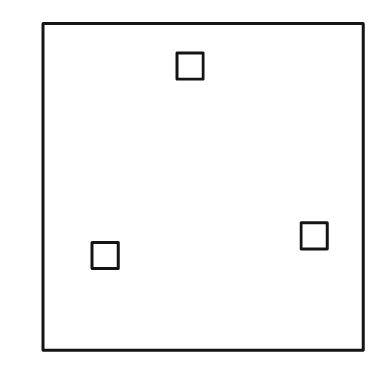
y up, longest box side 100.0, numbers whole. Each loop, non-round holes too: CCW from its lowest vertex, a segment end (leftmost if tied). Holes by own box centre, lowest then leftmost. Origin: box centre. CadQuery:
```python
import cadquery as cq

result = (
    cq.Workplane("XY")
    .moveTo(-49.0, -50.0)
    .lineTo(49.0, -50.0)
    .lineTo(49.0, 50.0)
    .lineTo(-49.0, 50.0)
    .close()
    .moveTo(-34.0, -25.0)
    .lineTo(-26.0, -25.0)
    .lineTo(-26.0, -17.0)
    .lineTo(-34.0, -17.0)
    .close()
    .moveTo(30.0, -19.0)
    .lineTo(38.0, -19.0)
    .lineTo(38.0, -11.0)
    .lineTo(30.0, -11.0)
    .close()
    .moveTo(-8.0, 33.0)
    .lineTo(0.0, 33.0)
    .lineTo(0.0, 41.0)
    .lineTo(-8.0, 41.0)
    .close()
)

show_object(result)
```